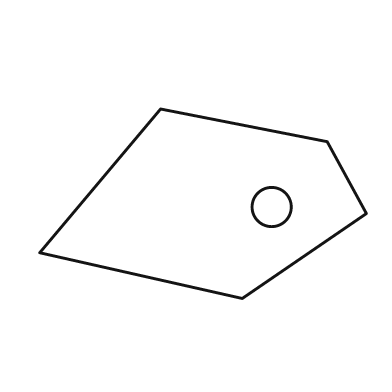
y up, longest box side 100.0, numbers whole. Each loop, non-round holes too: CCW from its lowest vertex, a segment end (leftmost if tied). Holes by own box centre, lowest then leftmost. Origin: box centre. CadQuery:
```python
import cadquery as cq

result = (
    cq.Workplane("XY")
    .moveTo(12.0, -29.0)
    .lineTo(50.0, -3.0)
    .lineTo(38.0, 19.0)
    .lineTo(-13.0, 29.0)
    .lineTo(-50.0, -15.0)
    .close()
    .moveTo(21.0, -1.0)
    .circle(6.0)
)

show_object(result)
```